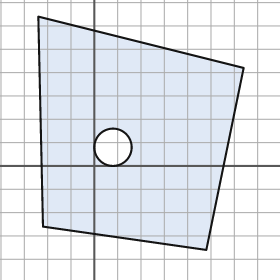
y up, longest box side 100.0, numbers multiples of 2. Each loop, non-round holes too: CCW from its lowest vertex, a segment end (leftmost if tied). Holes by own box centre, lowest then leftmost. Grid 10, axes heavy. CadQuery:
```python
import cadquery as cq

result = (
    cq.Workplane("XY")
    .moveTo(48.0, -36.0)
    .lineTo(64.0, 42.0)
    .lineTo(-24.0, 64.0)
    .lineTo(-22.0, -26.0)
    .close()
    .moveTo(8.0, 8.0)
    .circle(8.0)
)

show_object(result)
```